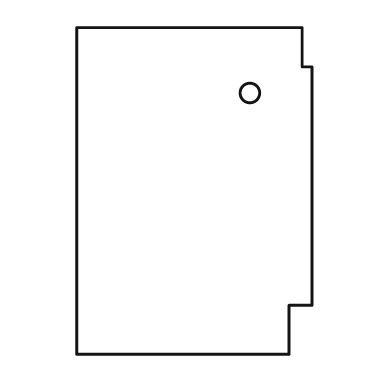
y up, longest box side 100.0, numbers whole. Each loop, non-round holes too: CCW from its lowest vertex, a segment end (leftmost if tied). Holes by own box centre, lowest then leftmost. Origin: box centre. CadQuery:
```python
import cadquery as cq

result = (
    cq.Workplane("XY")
    .moveTo(-36.0, -50.0)
    .lineTo(29.0, -50.0)
    .lineTo(29.0, -35.0)
    .lineTo(36.0, -35.0)
    .lineTo(36.0, 38.0)
    .lineTo(33.0, 38.0)
    .lineTo(33.0, 50.0)
    .lineTo(-36.0, 50.0)
    .close()
    .moveTo(17.0, 30.0)
    .circle(3.0)
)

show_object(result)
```